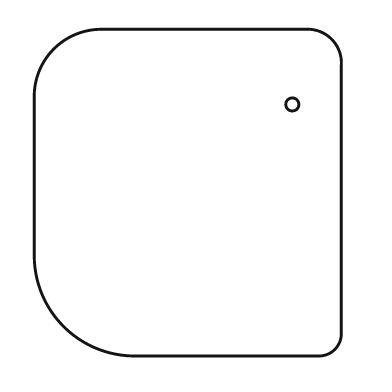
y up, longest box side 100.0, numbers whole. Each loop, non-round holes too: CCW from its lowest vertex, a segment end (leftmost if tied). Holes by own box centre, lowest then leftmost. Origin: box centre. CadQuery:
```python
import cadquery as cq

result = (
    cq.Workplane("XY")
    .moveTo(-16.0, -50.0)
    .lineTo(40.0, -50.0)
    .threePointArc((45.0, -48.0), (47.0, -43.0))
    .lineTo(47.0, 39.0)
    .threePointArc((44.0, 47.0), (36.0, 50.0))
    .lineTo(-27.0, 50.0)
    .threePointArc((-41.0, 44.0), (-47.0, 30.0))
    .lineTo(-47.0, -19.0)
    .threePointArc((-38.0, -41.0), (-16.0, -50.0))
    .close()
    .moveTo(32.0, 27.0)
    .circle(2.0)
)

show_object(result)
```